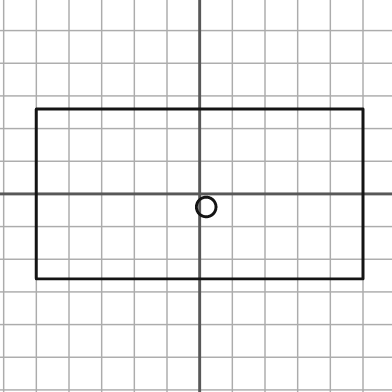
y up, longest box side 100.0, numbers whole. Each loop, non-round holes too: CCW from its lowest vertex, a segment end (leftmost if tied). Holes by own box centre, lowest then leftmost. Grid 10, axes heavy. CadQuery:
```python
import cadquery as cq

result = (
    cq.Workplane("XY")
    .moveTo(-50.0, -26.0)
    .lineTo(50.0, -26.0)
    .lineTo(50.0, 26.0)
    .lineTo(-50.0, 26.0)
    .close()
    .moveTo(2.0, -4.0)
    .circle(3.0)
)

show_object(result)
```